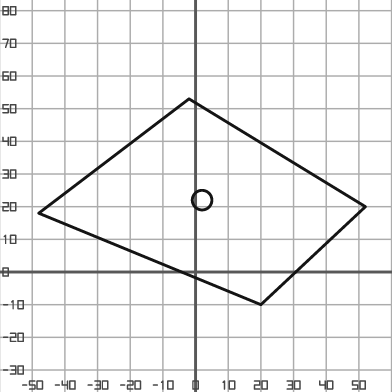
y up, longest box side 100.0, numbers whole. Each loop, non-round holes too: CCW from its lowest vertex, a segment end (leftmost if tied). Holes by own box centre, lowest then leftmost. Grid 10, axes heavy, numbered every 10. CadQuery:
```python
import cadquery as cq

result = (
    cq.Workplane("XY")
    .moveTo(20.0, -10.0)
    .lineTo(52.0, 20.0)
    .lineTo(-2.0, 53.0)
    .lineTo(-48.0, 18.0)
    .close()
    .moveTo(2.0, 22.0)
    .circle(3.0)
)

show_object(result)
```